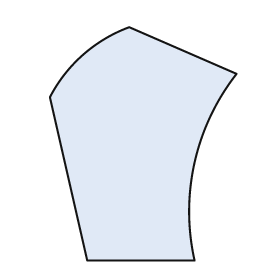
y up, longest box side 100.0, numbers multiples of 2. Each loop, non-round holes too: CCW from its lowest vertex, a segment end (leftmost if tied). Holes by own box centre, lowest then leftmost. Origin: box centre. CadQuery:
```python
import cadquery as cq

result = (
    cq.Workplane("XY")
    .moveTo(-24.0, -50.0)
    .lineTo(22.0, -50.0)
    .threePointArc((22.0, -8.0), (40.0, 30.0))
    .lineTo(-6.0, 50.0)
    .threePointArc((-26.0, 38.0), (-40.0, 20.0))
    .close()
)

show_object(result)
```